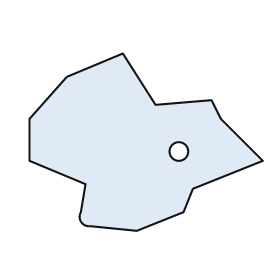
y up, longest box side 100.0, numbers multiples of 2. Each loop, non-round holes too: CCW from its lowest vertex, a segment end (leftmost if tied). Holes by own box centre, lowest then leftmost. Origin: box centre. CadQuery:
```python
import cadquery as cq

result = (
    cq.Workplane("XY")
    .moveTo(-4.0, -38.0)
    .lineTo(16.0, -30.0)
    .lineTo(20.0, -20.0)
    .lineTo(50.0, -8.0)
    .lineTo(32.0, 10.0)
    .lineTo(28.0, 18.0)
    .lineTo(4.0, 16.0)
    .lineTo(-10.0, 38.0)
    .lineTo(-34.0, 28.0)
    .lineTo(-50.0, 10.0)
    .lineTo(-50.0, -8.0)
    .lineTo(-26.0, -18.0)
    .lineTo(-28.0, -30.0)
    .threePointArc((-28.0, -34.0), (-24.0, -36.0))
    .close()
    .moveTo(14.0, -4.0)
    .circle(4.0)
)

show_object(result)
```